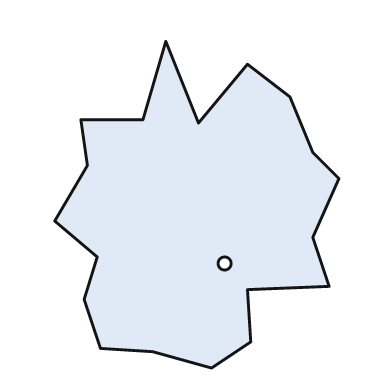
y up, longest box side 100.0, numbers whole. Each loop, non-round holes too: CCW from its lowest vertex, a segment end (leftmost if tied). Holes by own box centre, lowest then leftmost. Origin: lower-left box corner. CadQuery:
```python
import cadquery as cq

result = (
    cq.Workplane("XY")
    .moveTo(48.0, 0.0)
    .lineTo(60.0, 8.0)
    .lineTo(59.0, 24.0)
    .lineTo(84.0, 25.0)
    .lineTo(79.0, 40.0)
    .lineTo(87.0, 58.0)
    .lineTo(79.0, 66.0)
    .lineTo(72.0, 83.0)
    .lineTo(59.0, 93.0)
    .lineTo(44.0, 75.0)
    .lineTo(34.0, 100.0)
    .lineTo(27.0, 76.0)
    .lineTo(8.0, 76.0)
    .lineTo(10.0, 62.0)
    .lineTo(0.0, 45.0)
    .lineTo(13.0, 34.0)
    .lineTo(9.0, 21.0)
    .lineTo(14.0, 6.0)
    .lineTo(30.0, 5.0)
    .close()
    .moveTo(52.0, 32.0)
    .circle(2.0)
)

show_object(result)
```